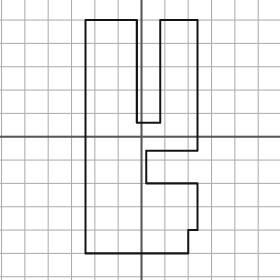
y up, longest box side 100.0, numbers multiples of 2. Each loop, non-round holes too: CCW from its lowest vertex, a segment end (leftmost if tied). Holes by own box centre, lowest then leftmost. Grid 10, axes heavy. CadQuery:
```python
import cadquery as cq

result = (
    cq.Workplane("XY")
    .moveTo(-24.0, -50.0)
    .lineTo(20.0, -50.0)
    .lineTo(20.0, -40.0)
    .lineTo(24.0, -40.0)
    .lineTo(24.0, -20.0)
    .lineTo(2.0, -20.0)
    .lineTo(2.0, -6.0)
    .lineTo(24.0, -6.0)
    .lineTo(24.0, 50.0)
    .lineTo(8.0, 50.0)
    .lineTo(8.0, 6.0)
    .lineTo(-2.0, 6.0)
    .lineTo(-2.0, 50.0)
    .lineTo(-24.0, 50.0)
    .close()
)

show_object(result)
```